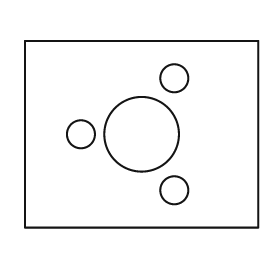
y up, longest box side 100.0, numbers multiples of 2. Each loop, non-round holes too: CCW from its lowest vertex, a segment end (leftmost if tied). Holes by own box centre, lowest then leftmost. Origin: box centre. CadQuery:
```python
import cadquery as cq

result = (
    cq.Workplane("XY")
    .moveTo(-50.0, -40.0)
    .lineTo(50.0, -40.0)
    .lineTo(50.0, 40.0)
    .lineTo(-50.0, 40.0)
    .close()
    .moveTo(14.0, -24.0)
    .circle(6.0)
    .moveTo(-26.0, 0.0)
    .circle(6.0)
    .moveTo(0.0, 0.0)
    .circle(16.0)
    .moveTo(14.0, 24.0)
    .circle(6.0)
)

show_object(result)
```